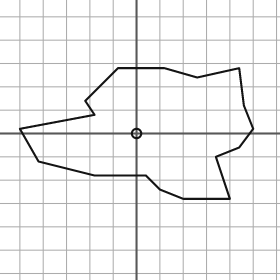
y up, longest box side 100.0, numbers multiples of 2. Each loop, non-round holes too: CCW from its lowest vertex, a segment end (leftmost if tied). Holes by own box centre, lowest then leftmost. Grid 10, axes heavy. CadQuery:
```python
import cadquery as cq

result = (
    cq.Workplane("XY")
    .moveTo(20.0, -28.0)
    .lineTo(40.0, -28.0)
    .lineTo(34.0, -10.0)
    .lineTo(44.0, -6.0)
    .lineTo(50.0, 2.0)
    .lineTo(46.0, 12.0)
    .lineTo(44.0, 28.0)
    .lineTo(26.0, 24.0)
    .lineTo(12.0, 28.0)
    .lineTo(-8.0, 28.0)
    .lineTo(-22.0, 14.0)
    .lineTo(-18.0, 8.0)
    .lineTo(-50.0, 2.0)
    .lineTo(-42.0, -12.0)
    .lineTo(-18.0, -18.0)
    .lineTo(4.0, -18.0)
    .lineTo(10.0, -24.0)
    .close()
    .moveTo(0.0, 0.0)
    .circle(2.0)
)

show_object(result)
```